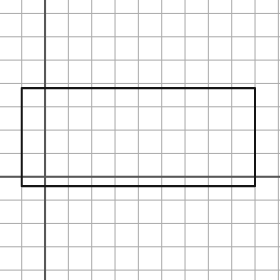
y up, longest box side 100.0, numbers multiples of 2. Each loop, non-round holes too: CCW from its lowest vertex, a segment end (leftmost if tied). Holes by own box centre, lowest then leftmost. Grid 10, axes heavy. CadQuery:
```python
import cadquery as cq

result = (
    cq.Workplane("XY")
    .moveTo(-10.0, -4.0)
    .lineTo(90.0, -4.0)
    .lineTo(90.0, 38.0)
    .lineTo(-10.0, 38.0)
    .close()
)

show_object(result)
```